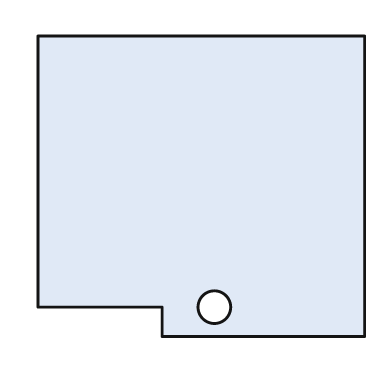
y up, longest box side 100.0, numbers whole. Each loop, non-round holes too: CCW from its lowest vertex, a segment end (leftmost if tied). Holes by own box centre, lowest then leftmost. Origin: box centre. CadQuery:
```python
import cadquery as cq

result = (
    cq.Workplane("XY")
    .moveTo(-12.0, -46.0)
    .lineTo(50.0, -46.0)
    .lineTo(50.0, 46.0)
    .lineTo(-50.0, 46.0)
    .lineTo(-50.0, -37.0)
    .lineTo(-12.0, -37.0)
    .close()
    .moveTo(4.0, -37.0)
    .circle(5.0)
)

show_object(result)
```